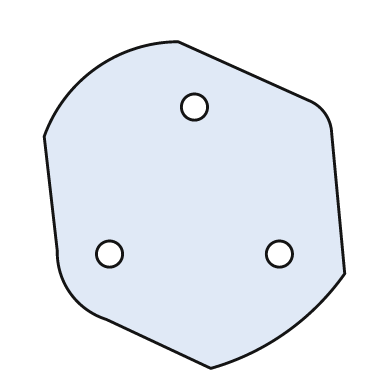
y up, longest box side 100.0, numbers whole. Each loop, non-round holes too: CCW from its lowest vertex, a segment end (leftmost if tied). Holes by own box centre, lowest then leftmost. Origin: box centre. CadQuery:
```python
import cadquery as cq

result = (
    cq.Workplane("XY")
    .moveTo(5.0, -50.0)
    .threePointArc((28.0, -39.0), (46.0, -21.0))
    .lineTo(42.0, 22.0)
    .threePointArc((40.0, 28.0), (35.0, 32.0))
    .lineTo(-5.0, 50.0)
    .threePointArc((-30.0, 42.0), (-46.0, 21.0))
    .lineTo(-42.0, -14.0)
    .threePointArc((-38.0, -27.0), (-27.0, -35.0))
    .close()
    .moveTo(-26.0, -15.0)
    .circle(4.0)
    .moveTo(26.0, -15.0)
    .circle(4.0)
    .moveTo(0.0, 30.0)
    .circle(4.0)
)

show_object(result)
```